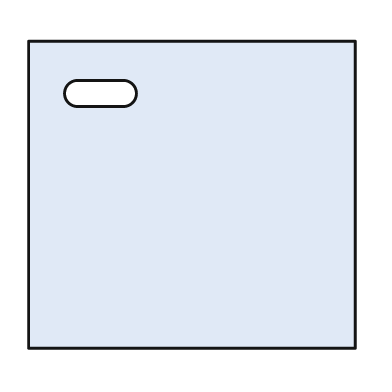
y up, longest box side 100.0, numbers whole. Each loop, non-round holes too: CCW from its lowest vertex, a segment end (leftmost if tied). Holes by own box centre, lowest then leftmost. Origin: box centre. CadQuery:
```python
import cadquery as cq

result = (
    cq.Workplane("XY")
    .moveTo(-50.0, -47.0)
    .lineTo(50.0, -47.0)
    .lineTo(50.0, 47.0)
    .lineTo(-50.0, 47.0)
    .close()
    .moveTo(-35.0, 27.0)
    .lineTo(-21.0, 27.0)
    .threePointArc((-17.0, 31.0), (-21.0, 35.0))
    .lineTo(-35.0, 35.0)
    .threePointArc((-39.0, 31.0), (-35.0, 27.0))
    .close()
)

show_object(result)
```